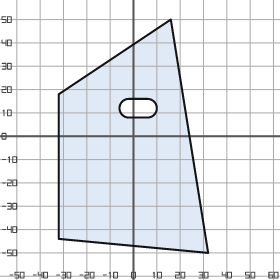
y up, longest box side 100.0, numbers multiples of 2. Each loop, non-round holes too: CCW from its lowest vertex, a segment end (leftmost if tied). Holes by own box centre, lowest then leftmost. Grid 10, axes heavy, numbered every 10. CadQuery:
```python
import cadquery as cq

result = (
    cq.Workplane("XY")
    .moveTo(32.0, -50.0)
    .lineTo(16.0, 50.0)
    .lineTo(-32.0, 18.0)
    .lineTo(-32.0, -44.0)
    .close()
    .moveTo(-2.0, 8.0)
    .lineTo(6.0, 8.0)
    .threePointArc((10.0, 12.0), (6.0, 16.0))
    .lineTo(-2.0, 16.0)
    .threePointArc((-6.0, 12.0), (-2.0, 8.0))
    .close()
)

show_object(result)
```